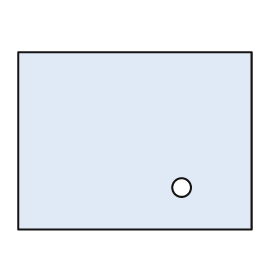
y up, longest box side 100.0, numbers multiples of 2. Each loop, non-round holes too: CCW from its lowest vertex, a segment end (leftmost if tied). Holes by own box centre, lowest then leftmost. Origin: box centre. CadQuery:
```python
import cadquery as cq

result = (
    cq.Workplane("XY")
    .moveTo(-50.0, -38.0)
    .lineTo(50.0, -38.0)
    .lineTo(50.0, 38.0)
    .lineTo(-50.0, 38.0)
    .close()
    .moveTo(20.0, -20.0)
    .circle(4.0)
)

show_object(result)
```